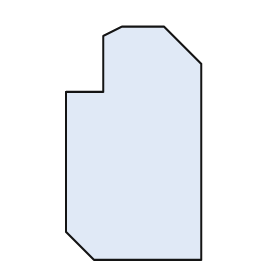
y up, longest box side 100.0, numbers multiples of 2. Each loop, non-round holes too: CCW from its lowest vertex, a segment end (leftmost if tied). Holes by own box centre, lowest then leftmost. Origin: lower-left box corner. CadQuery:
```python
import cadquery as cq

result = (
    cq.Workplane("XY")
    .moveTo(12.0, 0.0)
    .lineTo(58.0, 0.0)
    .lineTo(58.0, 84.0)
    .lineTo(42.0, 100.0)
    .lineTo(24.0, 100.0)
    .lineTo(16.0, 96.0)
    .lineTo(16.0, 72.0)
    .lineTo(0.0, 72.0)
    .lineTo(0.0, 12.0)
    .close()
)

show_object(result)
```